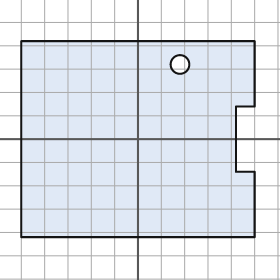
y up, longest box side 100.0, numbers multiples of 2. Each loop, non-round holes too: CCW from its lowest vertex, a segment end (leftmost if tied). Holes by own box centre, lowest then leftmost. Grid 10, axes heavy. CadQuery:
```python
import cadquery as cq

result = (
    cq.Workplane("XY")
    .moveTo(-50.0, -42.0)
    .lineTo(50.0, -42.0)
    .lineTo(50.0, -14.0)
    .lineTo(42.0, -14.0)
    .lineTo(42.0, 14.0)
    .lineTo(50.0, 14.0)
    .lineTo(50.0, 42.0)
    .lineTo(-50.0, 42.0)
    .close()
    .moveTo(18.0, 32.0)
    .circle(4.0)
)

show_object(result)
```